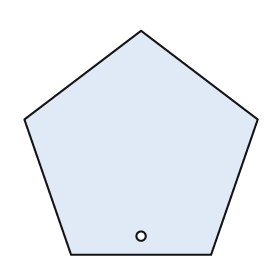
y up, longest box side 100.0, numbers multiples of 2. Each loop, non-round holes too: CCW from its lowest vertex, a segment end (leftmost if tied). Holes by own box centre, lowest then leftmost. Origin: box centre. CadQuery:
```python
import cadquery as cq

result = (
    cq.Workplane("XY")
    .moveTo(-30.0, -48.0)
    .lineTo(30.0, -48.0)
    .lineTo(50.0, 10.0)
    .lineTo(0.0, 48.0)
    .lineTo(-50.0, 10.0)
    .close()
    .moveTo(0.0, -40.0)
    .circle(2.0)
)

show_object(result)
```